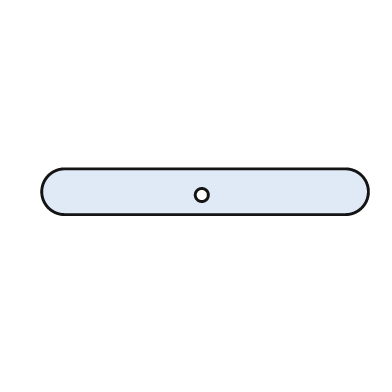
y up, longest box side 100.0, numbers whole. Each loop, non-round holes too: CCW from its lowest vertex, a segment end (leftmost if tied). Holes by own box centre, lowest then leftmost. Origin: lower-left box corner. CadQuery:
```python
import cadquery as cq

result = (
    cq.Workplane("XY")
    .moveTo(7.0, 0.0)
    .lineTo(93.0, 0.0)
    .threePointArc((100.0, 7.0), (93.0, 14.0))
    .lineTo(7.0, 14.0)
    .threePointArc((0.0, 7.0), (7.0, 0.0))
    .close()
    .moveTo(49.0, 6.0)
    .circle(2.0)
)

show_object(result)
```